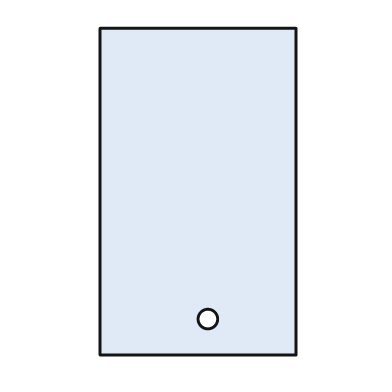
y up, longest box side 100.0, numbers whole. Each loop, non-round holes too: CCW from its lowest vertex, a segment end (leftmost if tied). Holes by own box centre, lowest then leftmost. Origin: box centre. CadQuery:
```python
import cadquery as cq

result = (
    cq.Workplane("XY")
    .moveTo(-30.0, -50.0)
    .lineTo(30.0, -50.0)
    .lineTo(30.0, 50.0)
    .lineTo(-30.0, 50.0)
    .close()
    .moveTo(3.0, -39.0)
    .circle(3.0)
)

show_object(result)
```